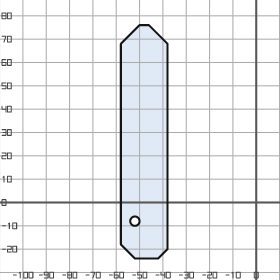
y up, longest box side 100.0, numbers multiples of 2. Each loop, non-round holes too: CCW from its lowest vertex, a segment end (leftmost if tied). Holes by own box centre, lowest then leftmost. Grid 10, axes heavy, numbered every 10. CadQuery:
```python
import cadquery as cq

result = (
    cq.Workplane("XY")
    .moveTo(-52.0, -24.0)
    .lineTo(-42.0, -24.0)
    .lineTo(-38.0, -20.0)
    .lineTo(-38.0, 68.0)
    .lineTo(-46.0, 76.0)
    .lineTo(-50.0, 76.0)
    .lineTo(-58.0, 68.0)
    .lineTo(-58.0, -18.0)
    .close()
    .moveTo(-52.0, -8.0)
    .circle(2.0)
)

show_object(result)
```